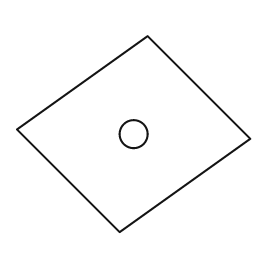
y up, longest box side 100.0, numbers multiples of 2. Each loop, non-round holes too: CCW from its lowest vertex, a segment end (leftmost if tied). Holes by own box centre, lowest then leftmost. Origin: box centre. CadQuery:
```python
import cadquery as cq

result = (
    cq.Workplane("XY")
    .moveTo(-6.0, -42.0)
    .lineTo(50.0, -2.0)
    .lineTo(6.0, 42.0)
    .lineTo(-50.0, 2.0)
    .close()
    .moveTo(0.0, 0.0)
    .circle(6.0)
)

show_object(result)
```